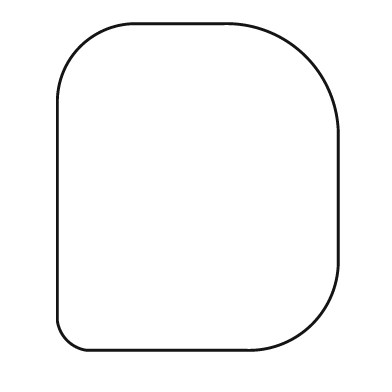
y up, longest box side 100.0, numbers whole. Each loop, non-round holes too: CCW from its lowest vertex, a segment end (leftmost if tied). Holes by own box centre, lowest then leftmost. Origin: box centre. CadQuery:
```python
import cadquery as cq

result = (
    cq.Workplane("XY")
    .moveTo(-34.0, -50.0)
    .lineTo(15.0, -50.0)
    .threePointArc((35.0, -42.0), (43.0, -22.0))
    .lineTo(43.0, 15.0)
    .threePointArc((33.0, 40.0), (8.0, 50.0))
    .lineTo(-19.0, 50.0)
    .threePointArc((-36.0, 43.0), (-43.0, 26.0))
    .lineTo(-43.0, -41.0)
    .threePointArc((-40.0, -47.0), (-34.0, -50.0))
    .close()
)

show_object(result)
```